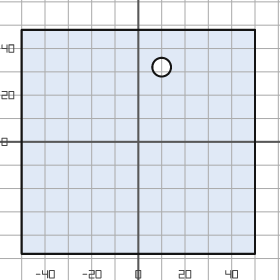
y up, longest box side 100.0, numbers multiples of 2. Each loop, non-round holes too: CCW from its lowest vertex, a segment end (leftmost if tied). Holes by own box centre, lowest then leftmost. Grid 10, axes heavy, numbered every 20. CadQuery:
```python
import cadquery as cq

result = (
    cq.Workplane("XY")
    .moveTo(-50.0, -48.0)
    .lineTo(50.0, -48.0)
    .lineTo(50.0, 48.0)
    .lineTo(-50.0, 48.0)
    .close()
    .moveTo(10.0, 32.0)
    .circle(4.0)
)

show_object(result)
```